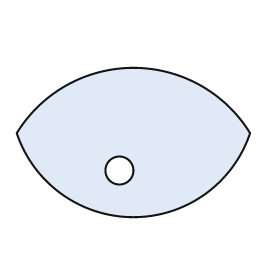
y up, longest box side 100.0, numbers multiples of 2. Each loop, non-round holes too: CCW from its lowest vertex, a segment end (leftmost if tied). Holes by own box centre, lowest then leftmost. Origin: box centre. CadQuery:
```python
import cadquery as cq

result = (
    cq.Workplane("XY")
    .moveTo(-50.0, 4.0)
    .threePointArc((0.0, -32.0), (50.0, 4.0))
    .threePointArc((0.0, 32.0), (-50.0, 4.0))
    .close()
    .moveTo(-6.0, -12.0)
    .circle(6.0)
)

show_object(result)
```